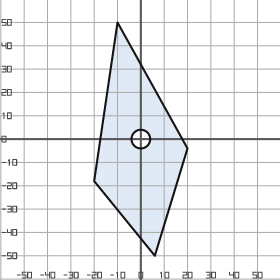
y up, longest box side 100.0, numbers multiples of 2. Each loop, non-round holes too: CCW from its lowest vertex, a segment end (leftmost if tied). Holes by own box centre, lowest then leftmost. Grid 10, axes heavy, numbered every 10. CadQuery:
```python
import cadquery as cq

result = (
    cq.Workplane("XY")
    .moveTo(6.0, -50.0)
    .lineTo(20.0, -4.0)
    .lineTo(-10.0, 50.0)
    .lineTo(-20.0, -18.0)
    .close()
    .moveTo(0.0, 0.0)
    .circle(4.0)
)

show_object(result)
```